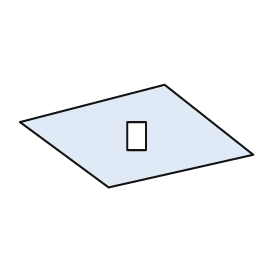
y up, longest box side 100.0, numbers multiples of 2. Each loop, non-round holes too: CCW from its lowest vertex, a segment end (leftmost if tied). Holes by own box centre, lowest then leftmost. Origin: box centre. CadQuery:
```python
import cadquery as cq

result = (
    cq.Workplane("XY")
    .moveTo(-12.0, -22.0)
    .lineTo(50.0, -8.0)
    .lineTo(12.0, 22.0)
    .lineTo(-50.0, 6.0)
    .close()
    .moveTo(-4.0, -6.0)
    .lineTo(4.0, -6.0)
    .lineTo(4.0, 6.0)
    .lineTo(-4.0, 6.0)
    .close()
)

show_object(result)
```